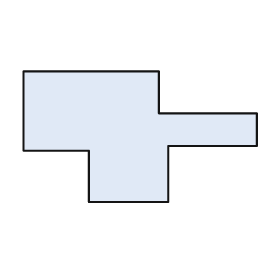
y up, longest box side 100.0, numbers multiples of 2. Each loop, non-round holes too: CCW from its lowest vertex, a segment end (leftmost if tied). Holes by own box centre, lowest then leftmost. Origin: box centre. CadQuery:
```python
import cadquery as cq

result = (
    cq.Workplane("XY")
    .moveTo(-22.0, -28.0)
    .lineTo(12.0, -28.0)
    .lineTo(12.0, -4.0)
    .lineTo(50.0, -4.0)
    .lineTo(50.0, 10.0)
    .lineTo(8.0, 10.0)
    .lineTo(8.0, 28.0)
    .lineTo(-50.0, 28.0)
    .lineTo(-50.0, -6.0)
    .lineTo(-22.0, -6.0)
    .close()
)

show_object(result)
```